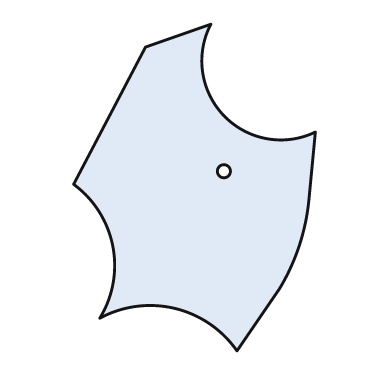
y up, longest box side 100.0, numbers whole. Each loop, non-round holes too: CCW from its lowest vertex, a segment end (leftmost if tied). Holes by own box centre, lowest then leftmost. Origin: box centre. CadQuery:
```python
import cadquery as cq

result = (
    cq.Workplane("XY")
    .moveTo(13.0, -50.0)
    .lineTo(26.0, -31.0)
    .threePointArc((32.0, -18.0), (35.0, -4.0))
    .lineTo(37.0, 17.0)
    .threePointArc((9.0, 22.0), (5.0, 50.0))
    .lineTo(-15.0, 43.0)
    .lineTo(-37.0, 1.0)
    .threePointArc((-25.0, -18.0), (-29.0, -40.0))
    .threePointArc((-6.0, -37.0), (13.0, -50.0))
    .close()
    .moveTo(9.0, 5.0)
    .circle(2.0)
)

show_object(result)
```